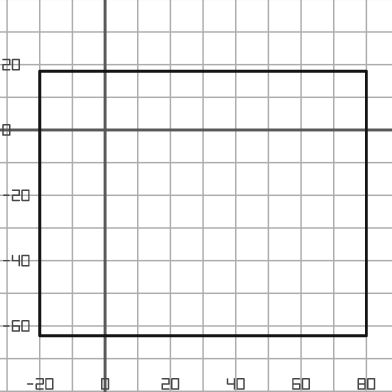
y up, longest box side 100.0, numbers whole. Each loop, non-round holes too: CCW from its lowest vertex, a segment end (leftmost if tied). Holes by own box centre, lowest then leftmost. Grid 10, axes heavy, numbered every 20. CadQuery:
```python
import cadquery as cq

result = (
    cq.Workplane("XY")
    .moveTo(-20.0, -63.0)
    .lineTo(80.0, -63.0)
    .lineTo(80.0, 18.0)
    .lineTo(-20.0, 18.0)
    .close()
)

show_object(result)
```